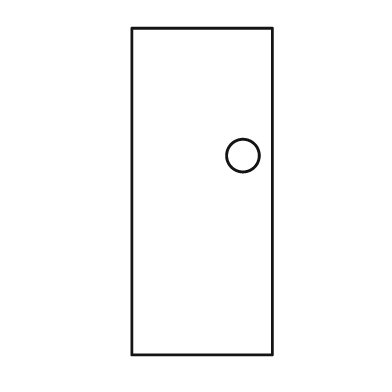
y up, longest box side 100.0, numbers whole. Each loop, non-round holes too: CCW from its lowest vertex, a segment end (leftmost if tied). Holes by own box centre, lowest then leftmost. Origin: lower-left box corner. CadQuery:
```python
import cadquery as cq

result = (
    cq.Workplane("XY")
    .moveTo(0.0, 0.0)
    .lineTo(43.0, 0.0)
    .lineTo(43.0, 100.0)
    .lineTo(0.0, 100.0)
    .close()
    .moveTo(34.0, 61.0)
    .circle(5.0)
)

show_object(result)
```